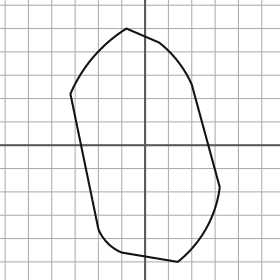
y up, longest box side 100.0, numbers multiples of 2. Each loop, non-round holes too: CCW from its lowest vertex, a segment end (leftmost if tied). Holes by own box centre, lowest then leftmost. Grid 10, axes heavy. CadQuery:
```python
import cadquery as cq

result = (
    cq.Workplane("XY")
    .moveTo(14.0, -50.0)
    .threePointArc((26.0, -36.0), (32.0, -18.0))
    .lineTo(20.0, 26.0)
    .threePointArc((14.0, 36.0), (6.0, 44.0))
    .lineTo(-8.0, 50.0)
    .threePointArc((-22.0, 38.0), (-32.0, 22.0))
    .lineTo(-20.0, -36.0)
    .threePointArc((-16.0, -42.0), (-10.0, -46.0))
    .close()
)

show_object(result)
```